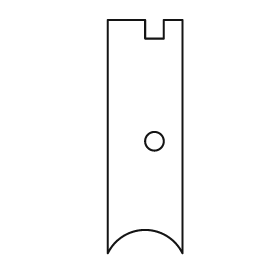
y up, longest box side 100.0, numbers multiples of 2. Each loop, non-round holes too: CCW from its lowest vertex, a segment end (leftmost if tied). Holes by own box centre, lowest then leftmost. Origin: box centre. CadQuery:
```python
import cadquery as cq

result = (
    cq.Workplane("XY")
    .moveTo(-16.0, -50.0)
    .threePointArc((0.0, -40.0), (16.0, -50.0))
    .lineTo(16.0, 50.0)
    .lineTo(8.0, 50.0)
    .lineTo(8.0, 42.0)
    .lineTo(0.0, 42.0)
    .lineTo(0.0, 50.0)
    .lineTo(-16.0, 50.0)
    .close()
    .moveTo(4.0, -2.0)
    .circle(4.0)
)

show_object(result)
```